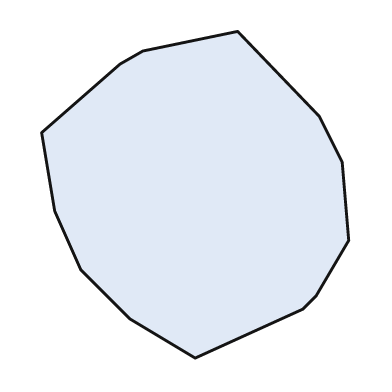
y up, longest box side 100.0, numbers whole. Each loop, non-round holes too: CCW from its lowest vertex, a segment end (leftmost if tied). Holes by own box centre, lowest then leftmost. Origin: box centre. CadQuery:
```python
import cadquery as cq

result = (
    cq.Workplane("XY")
    .moveTo(0.0, -50.0)
    .lineTo(33.0, -35.0)
    .lineTo(37.0, -31.0)
    .lineTo(47.0, -14.0)
    .lineTo(45.0, 10.0)
    .lineTo(38.0, 24.0)
    .lineTo(13.0, 50.0)
    .lineTo(-16.0, 44.0)
    .lineTo(-23.0, 40.0)
    .lineTo(-47.0, 19.0)
    .lineTo(-43.0, -5.0)
    .lineTo(-35.0, -23.0)
    .lineTo(-20.0, -38.0)
    .close()
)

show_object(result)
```